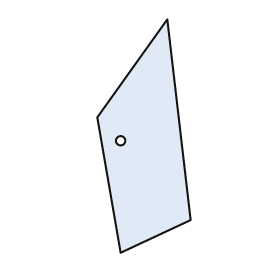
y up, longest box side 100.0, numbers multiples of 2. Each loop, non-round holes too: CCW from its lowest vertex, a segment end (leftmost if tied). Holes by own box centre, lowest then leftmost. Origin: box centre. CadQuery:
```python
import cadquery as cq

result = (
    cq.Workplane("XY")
    .moveTo(-10.0, -50.0)
    .lineTo(20.0, -36.0)
    .lineTo(10.0, 50.0)
    .lineTo(-20.0, 8.0)
    .close()
    .moveTo(-10.0, -2.0)
    .circle(2.0)
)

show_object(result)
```